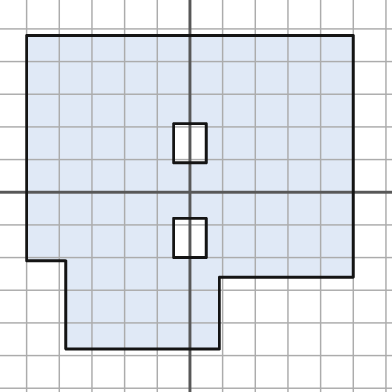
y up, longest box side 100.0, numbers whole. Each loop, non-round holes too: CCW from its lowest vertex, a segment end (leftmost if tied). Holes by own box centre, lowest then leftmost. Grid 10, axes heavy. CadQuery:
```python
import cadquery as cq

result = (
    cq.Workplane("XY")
    .moveTo(-38.0, -48.0)
    .lineTo(9.0, -48.0)
    .lineTo(9.0, -26.0)
    .lineTo(50.0, -26.0)
    .lineTo(50.0, 48.0)
    .lineTo(-50.0, 48.0)
    .lineTo(-50.0, -21.0)
    .lineTo(-38.0, -21.0)
    .close()
    .moveTo(-5.0, -20.0)
    .lineTo(5.0, -20.0)
    .lineTo(5.0, -8.0)
    .lineTo(-5.0, -8.0)
    .close()
    .moveTo(-5.0, 9.0)
    .lineTo(5.0, 9.0)
    .lineTo(5.0, 21.0)
    .lineTo(-5.0, 21.0)
    .close()
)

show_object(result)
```